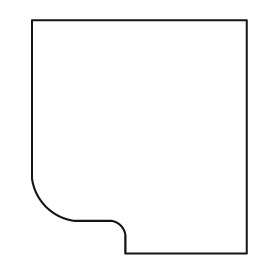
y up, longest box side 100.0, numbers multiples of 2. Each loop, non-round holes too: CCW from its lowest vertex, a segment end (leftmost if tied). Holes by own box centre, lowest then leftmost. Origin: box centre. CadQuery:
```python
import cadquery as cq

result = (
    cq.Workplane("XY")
    .moveTo(-6.0, -50.0)
    .lineTo(46.0, -50.0)
    .lineTo(46.0, 50.0)
    .lineTo(-46.0, 50.0)
    .lineTo(-46.0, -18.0)
    .threePointArc((-40.0, -30.0), (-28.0, -36.0))
    .lineTo(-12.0, -36.0)
    .threePointArc((-8.0, -38.0), (-6.0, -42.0))
    .close()
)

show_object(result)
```